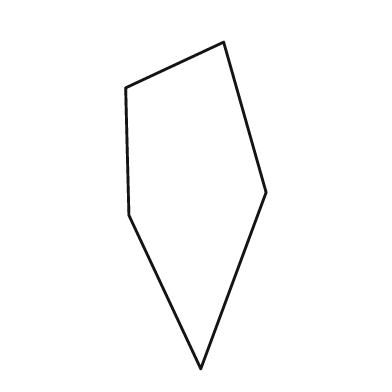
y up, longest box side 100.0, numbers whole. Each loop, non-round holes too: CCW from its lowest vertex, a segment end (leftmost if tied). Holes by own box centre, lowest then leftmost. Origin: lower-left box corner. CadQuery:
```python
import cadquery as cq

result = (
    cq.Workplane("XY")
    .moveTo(23.0, 0.0)
    .lineTo(43.0, 54.0)
    .lineTo(30.0, 100.0)
    .lineTo(0.0, 86.0)
    .lineTo(1.0, 47.0)
    .close()
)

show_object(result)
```